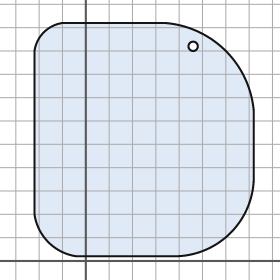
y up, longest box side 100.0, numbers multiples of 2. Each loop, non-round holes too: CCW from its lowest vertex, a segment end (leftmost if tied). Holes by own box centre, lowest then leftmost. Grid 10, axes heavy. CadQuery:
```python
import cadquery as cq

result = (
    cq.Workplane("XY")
    .moveTo(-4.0, 2.0)
    .lineTo(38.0, 2.0)
    .threePointArc((62.0, 12.0), (72.0, 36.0))
    .lineTo(72.0, 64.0)
    .threePointArc((60.0, 90.0), (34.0, 102.0))
    .lineTo(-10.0, 102.0)
    .threePointArc((-18.0, 98.0), (-22.0, 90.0))
    .lineTo(-22.0, 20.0)
    .threePointArc((-16.0, 8.0), (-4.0, 2.0))
    .close()
    .moveTo(46.0, 92.0)
    .circle(2.0)
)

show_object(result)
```